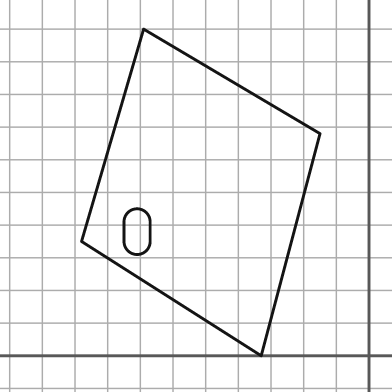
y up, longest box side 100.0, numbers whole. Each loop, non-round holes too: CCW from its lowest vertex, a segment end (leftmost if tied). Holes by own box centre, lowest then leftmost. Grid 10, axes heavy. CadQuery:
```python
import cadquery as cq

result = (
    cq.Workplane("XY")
    .moveTo(-33.0, 0.0)
    .lineTo(-15.0, 68.0)
    .lineTo(-69.0, 100.0)
    .lineTo(-88.0, 35.0)
    .close()
    .moveTo(-75.0, 35.0)
    .threePointArc((-71.0, 31.0), (-67.0, 35.0))
    .lineTo(-67.0, 41.0)
    .threePointArc((-71.0, 45.0), (-75.0, 41.0))
    .close()
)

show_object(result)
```